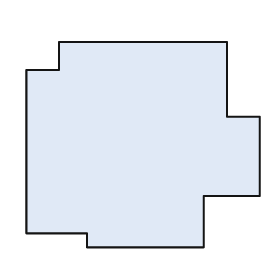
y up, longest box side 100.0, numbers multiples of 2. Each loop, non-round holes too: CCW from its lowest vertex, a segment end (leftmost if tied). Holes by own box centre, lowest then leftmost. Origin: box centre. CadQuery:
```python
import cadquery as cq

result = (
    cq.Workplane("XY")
    .moveTo(-24.0, -44.0)
    .lineTo(26.0, -44.0)
    .lineTo(26.0, -22.0)
    .lineTo(50.0, -22.0)
    .lineTo(50.0, 12.0)
    .lineTo(36.0, 12.0)
    .lineTo(36.0, 44.0)
    .lineTo(-36.0, 44.0)
    .lineTo(-36.0, 32.0)
    .lineTo(-50.0, 32.0)
    .lineTo(-50.0, -38.0)
    .lineTo(-24.0, -38.0)
    .close()
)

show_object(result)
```